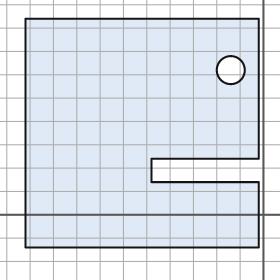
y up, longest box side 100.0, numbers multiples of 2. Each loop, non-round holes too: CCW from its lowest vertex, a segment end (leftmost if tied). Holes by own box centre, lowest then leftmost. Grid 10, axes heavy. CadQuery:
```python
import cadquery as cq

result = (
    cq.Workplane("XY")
    .moveTo(-102.0, -14.0)
    .lineTo(-2.0, -14.0)
    .lineTo(-2.0, 14.0)
    .lineTo(-48.0, 14.0)
    .lineTo(-48.0, 24.0)
    .lineTo(-2.0, 24.0)
    .lineTo(-2.0, 84.0)
    .lineTo(-102.0, 84.0)
    .close()
    .moveTo(-14.0, 62.0)
    .circle(6.0)
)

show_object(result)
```